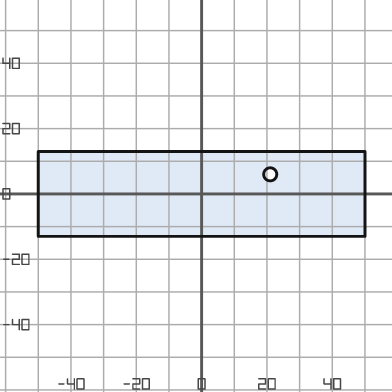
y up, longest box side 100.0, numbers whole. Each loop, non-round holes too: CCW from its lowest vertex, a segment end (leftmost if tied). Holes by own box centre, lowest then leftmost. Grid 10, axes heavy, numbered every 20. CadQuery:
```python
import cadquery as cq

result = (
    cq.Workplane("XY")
    .moveTo(-50.0, -13.0)
    .lineTo(50.0, -13.0)
    .lineTo(50.0, 13.0)
    .lineTo(-50.0, 13.0)
    .close()
    .moveTo(21.0, 6.0)
    .circle(2.0)
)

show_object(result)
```